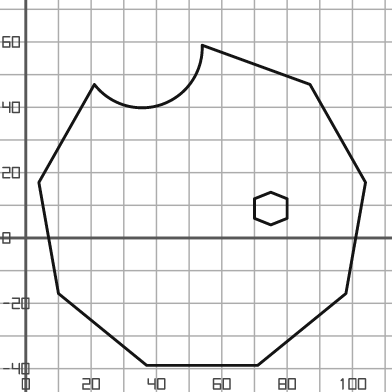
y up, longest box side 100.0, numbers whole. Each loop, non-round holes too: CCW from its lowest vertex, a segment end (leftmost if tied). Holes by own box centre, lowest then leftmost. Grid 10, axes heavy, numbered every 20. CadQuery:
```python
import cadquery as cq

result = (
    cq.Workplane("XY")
    .moveTo(37.0, -39.0)
    .lineTo(71.0, -39.0)
    .lineTo(98.0, -17.0)
    .lineTo(104.0, 17.0)
    .lineTo(87.0, 47.0)
    .lineTo(54.0, 59.0)
    .threePointArc((42.0, 41.0), (21.0, 47.0))
    .lineTo(4.0, 17.0)
    .lineTo(10.0, -17.0)
    .close()
    .moveTo(75.0, 4.0)
    .lineTo(80.0, 6.0)
    .lineTo(80.0, 12.0)
    .lineTo(75.0, 14.0)
    .lineTo(70.0, 12.0)
    .lineTo(70.0, 6.0)
    .close()
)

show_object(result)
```